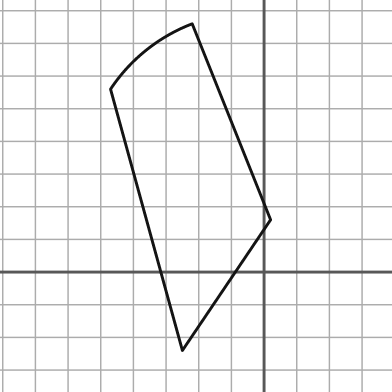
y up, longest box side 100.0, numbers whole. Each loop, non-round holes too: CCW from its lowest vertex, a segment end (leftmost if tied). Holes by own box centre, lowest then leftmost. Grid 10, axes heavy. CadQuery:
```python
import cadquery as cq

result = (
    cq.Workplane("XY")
    .moveTo(-25.0, -24.0)
    .lineTo(2.0, 16.0)
    .lineTo(-22.0, 76.0)
    .threePointArc((-36.0, 68.0), (-47.0, 56.0))
    .close()
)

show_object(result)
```